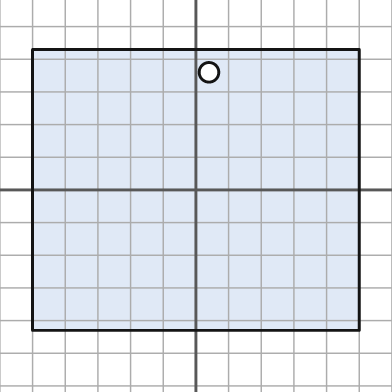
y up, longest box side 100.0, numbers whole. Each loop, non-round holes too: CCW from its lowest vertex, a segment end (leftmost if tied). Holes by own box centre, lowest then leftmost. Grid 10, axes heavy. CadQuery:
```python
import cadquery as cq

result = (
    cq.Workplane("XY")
    .moveTo(-50.0, -43.0)
    .lineTo(50.0, -43.0)
    .lineTo(50.0, 43.0)
    .lineTo(-50.0, 43.0)
    .close()
    .moveTo(4.0, 36.0)
    .circle(3.0)
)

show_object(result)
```